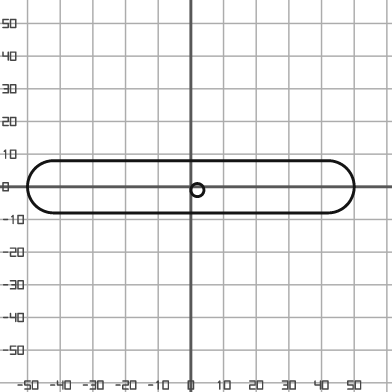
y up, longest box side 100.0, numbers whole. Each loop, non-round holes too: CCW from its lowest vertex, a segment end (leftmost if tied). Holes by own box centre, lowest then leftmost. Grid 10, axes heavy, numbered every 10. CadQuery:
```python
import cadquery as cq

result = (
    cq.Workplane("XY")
    .moveTo(-42.0, -8.0)
    .lineTo(42.0, -8.0)
    .threePointArc((50.0, 0.0), (42.0, 8.0))
    .lineTo(-42.0, 8.0)
    .threePointArc((-50.0, 0.0), (-42.0, -8.0))
    .close()
    .moveTo(2.0, -1.0)
    .circle(2.0)
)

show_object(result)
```